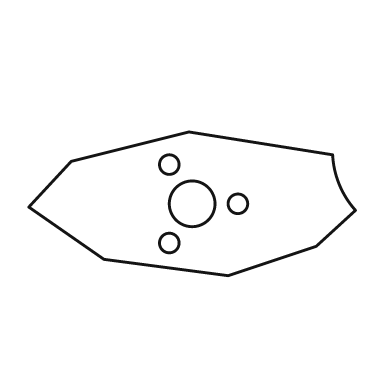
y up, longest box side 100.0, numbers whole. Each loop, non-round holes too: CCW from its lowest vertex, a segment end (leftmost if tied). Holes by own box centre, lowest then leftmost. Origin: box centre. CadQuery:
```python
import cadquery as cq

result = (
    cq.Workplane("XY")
    .moveTo(11.0, -22.0)
    .lineTo(38.0, -13.0)
    .lineTo(50.0, -2.0)
    .threePointArc((45.0, 6.0), (43.0, 15.0))
    .lineTo(-1.0, 22.0)
    .lineTo(-37.0, 13.0)
    .lineTo(-50.0, -1.0)
    .lineTo(-27.0, -17.0)
    .close()
    .moveTo(-7.0, -12.0)
    .circle(3.0)
    .moveTo(0.0, 0.0)
    .circle(7.0)
    .moveTo(14.0, 0.0)
    .circle(3.0)
    .moveTo(-7.0, 12.0)
    .circle(3.0)
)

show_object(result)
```